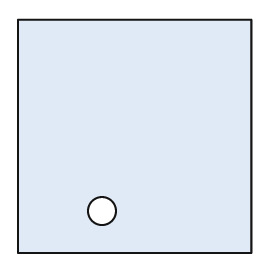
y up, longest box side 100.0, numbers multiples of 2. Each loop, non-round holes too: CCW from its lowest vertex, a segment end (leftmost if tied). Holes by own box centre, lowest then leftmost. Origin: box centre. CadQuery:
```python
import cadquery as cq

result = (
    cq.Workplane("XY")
    .moveTo(-50.0, -50.0)
    .lineTo(50.0, -50.0)
    .lineTo(50.0, 50.0)
    .lineTo(-50.0, 50.0)
    .close()
    .moveTo(-14.0, -32.0)
    .circle(6.0)
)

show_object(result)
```